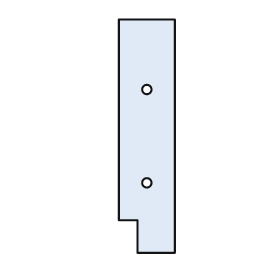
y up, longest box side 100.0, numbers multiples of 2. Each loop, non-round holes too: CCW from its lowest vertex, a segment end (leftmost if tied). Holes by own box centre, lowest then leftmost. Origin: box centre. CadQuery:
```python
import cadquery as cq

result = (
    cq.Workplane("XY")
    .moveTo(-4.0, -50.0)
    .lineTo(12.0, -50.0)
    .lineTo(12.0, 50.0)
    .lineTo(-12.0, 50.0)
    .lineTo(-12.0, -36.0)
    .lineTo(-4.0, -36.0)
    .close()
    .moveTo(0.0, -20.0)
    .circle(2.0)
    .moveTo(0.0, 20.0)
    .circle(2.0)
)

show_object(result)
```